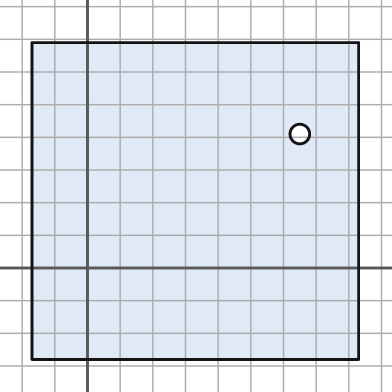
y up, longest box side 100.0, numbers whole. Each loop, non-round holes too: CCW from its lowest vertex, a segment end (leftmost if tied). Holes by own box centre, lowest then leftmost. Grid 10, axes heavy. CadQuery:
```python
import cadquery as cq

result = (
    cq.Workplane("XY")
    .moveTo(-17.0, -28.0)
    .lineTo(83.0, -28.0)
    .lineTo(83.0, 69.0)
    .lineTo(-17.0, 69.0)
    .close()
    .moveTo(65.0, 41.0)
    .circle(3.0)
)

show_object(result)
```